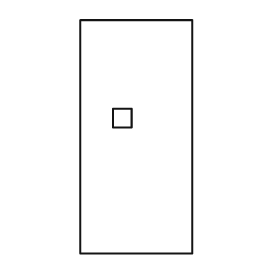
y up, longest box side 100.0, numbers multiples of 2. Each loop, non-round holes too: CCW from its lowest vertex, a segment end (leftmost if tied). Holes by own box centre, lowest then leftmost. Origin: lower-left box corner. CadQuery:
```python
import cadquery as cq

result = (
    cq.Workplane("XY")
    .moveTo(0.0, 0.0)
    .lineTo(48.0, 0.0)
    .lineTo(48.0, 100.0)
    .lineTo(0.0, 100.0)
    .close()
    .moveTo(14.0, 54.0)
    .lineTo(22.0, 54.0)
    .lineTo(22.0, 62.0)
    .lineTo(14.0, 62.0)
    .close()
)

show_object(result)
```